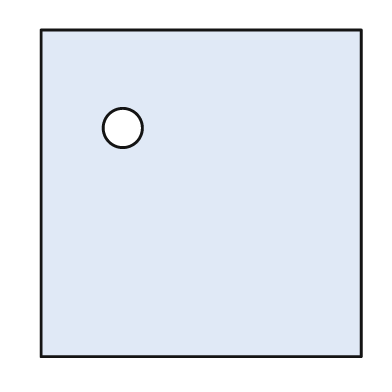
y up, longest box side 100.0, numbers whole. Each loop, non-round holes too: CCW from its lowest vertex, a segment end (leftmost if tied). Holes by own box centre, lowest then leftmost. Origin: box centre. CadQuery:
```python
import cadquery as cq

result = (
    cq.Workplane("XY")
    .moveTo(-49.0, -50.0)
    .lineTo(49.0, -50.0)
    .lineTo(49.0, 50.0)
    .lineTo(-49.0, 50.0)
    .close()
    .moveTo(-24.0, 20.0)
    .circle(6.0)
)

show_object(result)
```